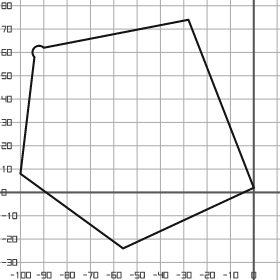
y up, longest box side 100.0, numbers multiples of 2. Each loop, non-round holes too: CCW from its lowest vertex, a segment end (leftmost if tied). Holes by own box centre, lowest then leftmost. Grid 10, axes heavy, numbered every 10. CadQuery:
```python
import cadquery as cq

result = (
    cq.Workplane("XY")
    .moveTo(-56.0, -24.0)
    .lineTo(0.0, 2.0)
    .lineTo(-28.0, 74.0)
    .lineTo(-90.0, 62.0)
    .threePointArc((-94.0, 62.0), (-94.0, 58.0))
    .lineTo(-100.0, 8.0)
    .close()
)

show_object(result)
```